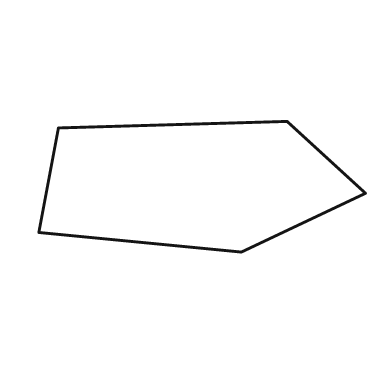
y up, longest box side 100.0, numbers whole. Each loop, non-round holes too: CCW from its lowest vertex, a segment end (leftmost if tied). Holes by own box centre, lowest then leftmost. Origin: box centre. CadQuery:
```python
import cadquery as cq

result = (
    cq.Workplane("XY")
    .moveTo(12.0, -20.0)
    .lineTo(50.0, -2.0)
    .lineTo(26.0, 20.0)
    .lineTo(-44.0, 18.0)
    .lineTo(-50.0, -14.0)
    .close()
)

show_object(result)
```